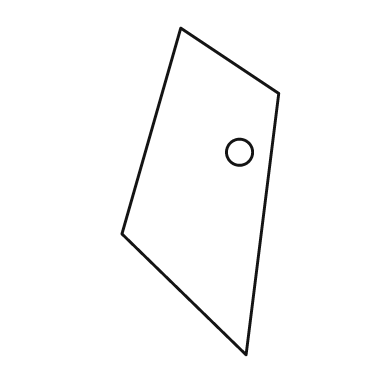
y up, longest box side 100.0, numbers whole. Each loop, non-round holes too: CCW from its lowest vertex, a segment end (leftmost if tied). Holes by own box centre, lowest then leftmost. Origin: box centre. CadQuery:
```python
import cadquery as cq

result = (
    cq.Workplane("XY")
    .moveTo(14.0, -50.0)
    .lineTo(24.0, 30.0)
    .lineTo(-6.0, 50.0)
    .lineTo(-24.0, -13.0)
    .close()
    .moveTo(12.0, 12.0)
    .circle(4.0)
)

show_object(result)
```